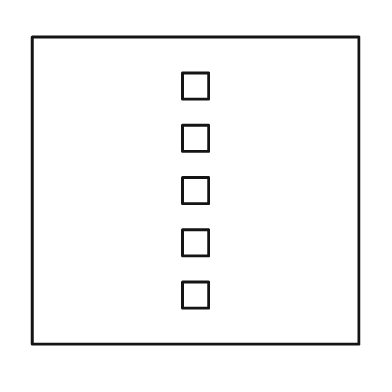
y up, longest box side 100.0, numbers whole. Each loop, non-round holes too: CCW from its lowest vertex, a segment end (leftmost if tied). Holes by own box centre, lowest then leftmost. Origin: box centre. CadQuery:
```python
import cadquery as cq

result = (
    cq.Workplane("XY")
    .moveTo(-50.0, -47.0)
    .lineTo(50.0, -47.0)
    .lineTo(50.0, 47.0)
    .lineTo(-50.0, 47.0)
    .close()
    .moveTo(-4.0, -36.0)
    .lineTo(4.0, -36.0)
    .lineTo(4.0, -28.0)
    .lineTo(-4.0, -28.0)
    .close()
    .moveTo(-4.0, -20.0)
    .lineTo(4.0, -20.0)
    .lineTo(4.0, -12.0)
    .lineTo(-4.0, -12.0)
    .close()
    .moveTo(-4.0, -4.0)
    .lineTo(4.0, -4.0)
    .lineTo(4.0, 4.0)
    .lineTo(-4.0, 4.0)
    .close()
    .moveTo(-4.0, 12.0)
    .lineTo(4.0, 12.0)
    .lineTo(4.0, 20.0)
    .lineTo(-4.0, 20.0)
    .close()
    .moveTo(-4.0, 28.0)
    .lineTo(4.0, 28.0)
    .lineTo(4.0, 36.0)
    .lineTo(-4.0, 36.0)
    .close()
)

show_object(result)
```